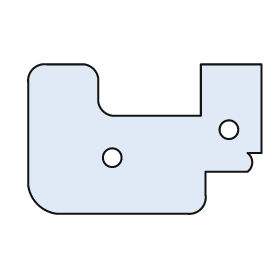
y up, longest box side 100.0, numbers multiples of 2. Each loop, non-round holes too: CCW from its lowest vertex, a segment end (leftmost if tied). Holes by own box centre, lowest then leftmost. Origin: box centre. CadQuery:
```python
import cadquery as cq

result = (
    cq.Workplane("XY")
    .moveTo(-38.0, -32.0)
    .lineTo(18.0, -32.0)
    .threePointArc((24.0, -30.0), (26.0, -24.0))
    .lineTo(26.0, -14.0)
    .lineTo(44.0, -14.0)
    .threePointArc((46.0, -10.0), (44.0, -6.0))
    .lineTo(50.0, -6.0)
    .lineTo(50.0, 32.0)
    .lineTo(24.0, 32.0)
    .lineTo(24.0, 10.0)
    .lineTo(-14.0, 10.0)
    .threePointArc((-18.0, 12.0), (-20.0, 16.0))
    .lineTo(-20.0, 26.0)
    .threePointArc((-22.0, 30.0), (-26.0, 32.0))
    .lineTo(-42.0, 32.0)
    .threePointArc((-48.0, 30.0), (-50.0, 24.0))
    .lineTo(-50.0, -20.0)
    .threePointArc((-46.0, -28.0), (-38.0, -32.0))
    .close()
    .moveTo(-14.0, -8.0)
    .circle(4.0)
    .moveTo(36.0, 4.0)
    .circle(4.0)
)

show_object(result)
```